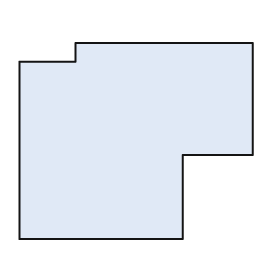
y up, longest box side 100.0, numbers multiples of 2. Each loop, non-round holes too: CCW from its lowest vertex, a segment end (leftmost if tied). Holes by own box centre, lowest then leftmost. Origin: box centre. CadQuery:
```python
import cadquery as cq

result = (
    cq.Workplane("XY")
    .moveTo(-50.0, -42.0)
    .lineTo(20.0, -42.0)
    .lineTo(20.0, -6.0)
    .lineTo(50.0, -6.0)
    .lineTo(50.0, 42.0)
    .lineTo(-26.0, 42.0)
    .lineTo(-26.0, 34.0)
    .lineTo(-50.0, 34.0)
    .close()
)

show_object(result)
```